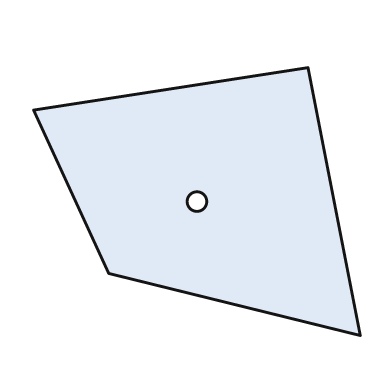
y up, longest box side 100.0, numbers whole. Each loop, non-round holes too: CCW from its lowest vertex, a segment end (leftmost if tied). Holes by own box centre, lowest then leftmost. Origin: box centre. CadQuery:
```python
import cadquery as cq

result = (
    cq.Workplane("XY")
    .moveTo(50.0, -41.0)
    .lineTo(34.0, 41.0)
    .lineTo(-50.0, 28.0)
    .lineTo(-27.0, -22.0)
    .close()
    .moveTo(0.0, 0.0)
    .circle(3.0)
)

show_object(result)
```